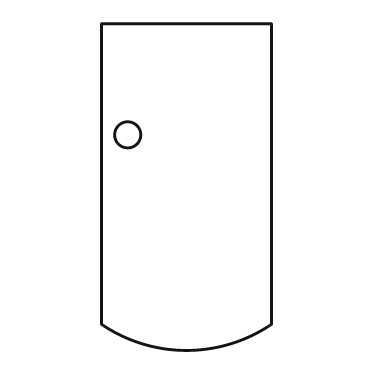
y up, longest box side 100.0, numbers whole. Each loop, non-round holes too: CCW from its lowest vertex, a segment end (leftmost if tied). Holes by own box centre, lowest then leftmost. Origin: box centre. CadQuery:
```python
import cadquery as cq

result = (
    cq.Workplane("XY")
    .moveTo(-26.0, -42.0)
    .threePointArc((0.0, -50.0), (26.0, -42.0))
    .lineTo(26.0, 50.0)
    .lineTo(-26.0, 50.0)
    .close()
    .moveTo(-18.0, 16.0)
    .circle(4.0)
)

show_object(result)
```